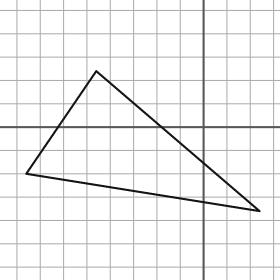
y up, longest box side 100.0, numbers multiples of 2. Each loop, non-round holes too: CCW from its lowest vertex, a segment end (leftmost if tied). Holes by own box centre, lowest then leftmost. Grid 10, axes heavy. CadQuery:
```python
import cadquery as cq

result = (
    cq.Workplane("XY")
    .moveTo(24.0, -36.0)
    .lineTo(-46.0, 24.0)
    .lineTo(-76.0, -20.0)
    .close()
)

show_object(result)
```